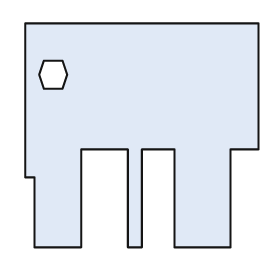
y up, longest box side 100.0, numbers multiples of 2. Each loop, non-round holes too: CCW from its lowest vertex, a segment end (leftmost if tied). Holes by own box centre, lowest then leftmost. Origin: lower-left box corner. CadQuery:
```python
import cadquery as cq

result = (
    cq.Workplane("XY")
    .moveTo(4.0, 0.0)
    .lineTo(24.0, 0.0)
    .lineTo(24.0, 42.0)
    .lineTo(44.0, 42.0)
    .lineTo(44.0, 0.0)
    .lineTo(50.0, 0.0)
    .lineTo(50.0, 42.0)
    .lineTo(64.0, 42.0)
    .lineTo(64.0, 0.0)
    .lineTo(88.0, 0.0)
    .lineTo(88.0, 42.0)
    .lineTo(100.0, 42.0)
    .lineTo(100.0, 96.0)
    .lineTo(0.0, 96.0)
    .lineTo(0.0, 30.0)
    .lineTo(4.0, 30.0)
    .close()
    .moveTo(8.0, 68.0)
    .lineTo(16.0, 68.0)
    .lineTo(18.0, 74.0)
    .lineTo(16.0, 80.0)
    .lineTo(8.0, 80.0)
    .lineTo(6.0, 74.0)
    .close()
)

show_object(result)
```